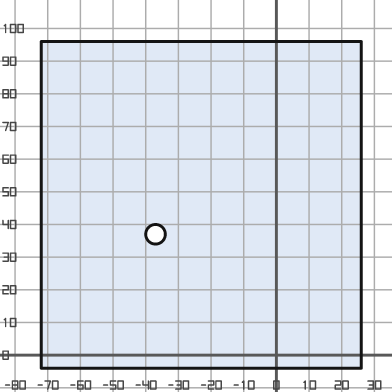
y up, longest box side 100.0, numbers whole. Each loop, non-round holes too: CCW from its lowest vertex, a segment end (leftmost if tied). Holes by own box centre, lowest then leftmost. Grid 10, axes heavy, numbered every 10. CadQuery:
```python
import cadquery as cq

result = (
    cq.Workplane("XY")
    .moveTo(-72.0, -4.0)
    .lineTo(26.0, -4.0)
    .lineTo(26.0, 96.0)
    .lineTo(-72.0, 96.0)
    .close()
    .moveTo(-37.0, 37.0)
    .circle(3.0)
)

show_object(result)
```